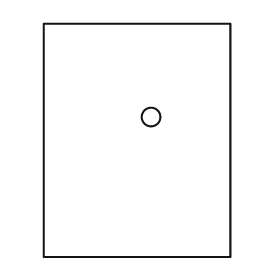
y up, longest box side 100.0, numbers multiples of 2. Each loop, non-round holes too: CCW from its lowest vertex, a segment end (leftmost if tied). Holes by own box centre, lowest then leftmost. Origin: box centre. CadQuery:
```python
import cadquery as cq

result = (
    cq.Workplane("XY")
    .moveTo(-40.0, -50.0)
    .lineTo(40.0, -50.0)
    .lineTo(40.0, 50.0)
    .lineTo(-40.0, 50.0)
    .close()
    .moveTo(6.0, 10.0)
    .circle(4.0)
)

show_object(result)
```